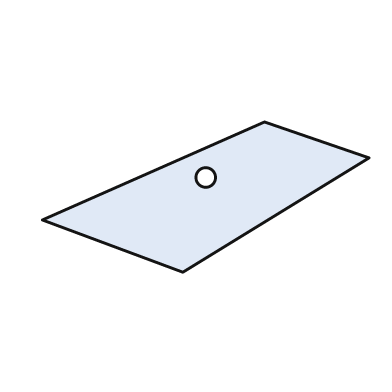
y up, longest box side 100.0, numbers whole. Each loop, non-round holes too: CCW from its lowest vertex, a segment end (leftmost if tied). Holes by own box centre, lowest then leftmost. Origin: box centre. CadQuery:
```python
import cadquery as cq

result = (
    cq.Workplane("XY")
    .moveTo(-7.0, -23.0)
    .lineTo(50.0, 12.0)
    .lineTo(18.0, 23.0)
    .lineTo(-50.0, -7.0)
    .close()
    .moveTo(0.0, 6.0)
    .circle(3.0)
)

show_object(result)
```